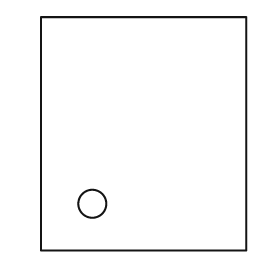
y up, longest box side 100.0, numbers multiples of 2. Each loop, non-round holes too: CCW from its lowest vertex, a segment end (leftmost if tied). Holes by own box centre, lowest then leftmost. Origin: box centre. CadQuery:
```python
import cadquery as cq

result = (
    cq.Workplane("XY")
    .moveTo(-44.0, -50.0)
    .lineTo(44.0, -50.0)
    .lineTo(44.0, 50.0)
    .lineTo(-44.0, 50.0)
    .close()
    .moveTo(-22.0, -30.0)
    .circle(6.0)
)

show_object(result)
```